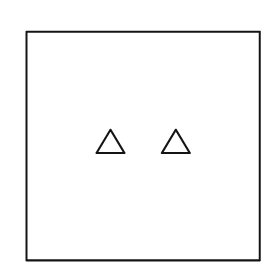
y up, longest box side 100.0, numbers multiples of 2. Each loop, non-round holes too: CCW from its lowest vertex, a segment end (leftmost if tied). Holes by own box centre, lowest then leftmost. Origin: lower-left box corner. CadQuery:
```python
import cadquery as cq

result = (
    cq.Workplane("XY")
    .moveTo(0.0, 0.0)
    .lineTo(100.0, 0.0)
    .lineTo(100.0, 98.0)
    .lineTo(0.0, 98.0)
    .close()
    .moveTo(30.0, 46.0)
    .lineTo(42.0, 46.0)
    .lineTo(36.0, 56.0)
    .close()
    .moveTo(58.0, 46.0)
    .lineTo(70.0, 46.0)
    .lineTo(64.0, 56.0)
    .close()
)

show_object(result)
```